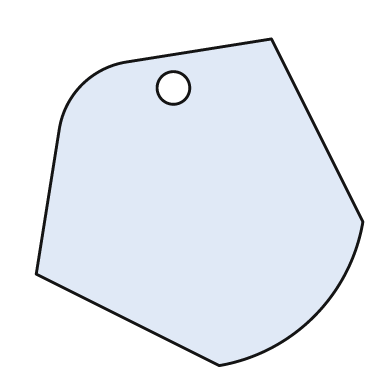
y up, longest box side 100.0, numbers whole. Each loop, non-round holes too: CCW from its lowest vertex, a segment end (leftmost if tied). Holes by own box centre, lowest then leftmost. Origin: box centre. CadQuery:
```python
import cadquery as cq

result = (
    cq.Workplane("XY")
    .moveTo(6.0, -50.0)
    .threePointArc((35.0, -35.0), (50.0, -6.0))
    .lineTo(22.0, 50.0)
    .lineTo(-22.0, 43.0)
    .threePointArc((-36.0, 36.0), (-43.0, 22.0))
    .lineTo(-50.0, -22.0)
    .close()
    .moveTo(-8.0, 35.0)
    .circle(5.0)
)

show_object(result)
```